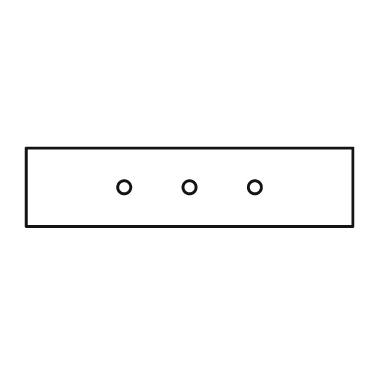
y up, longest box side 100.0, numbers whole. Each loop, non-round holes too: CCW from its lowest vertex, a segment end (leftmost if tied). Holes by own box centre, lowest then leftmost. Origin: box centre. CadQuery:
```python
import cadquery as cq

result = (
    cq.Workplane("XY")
    .moveTo(-50.0, -12.0)
    .lineTo(50.0, -12.0)
    .lineTo(50.0, 12.0)
    .lineTo(-50.0, 12.0)
    .close()
    .moveTo(-20.0, 0.0)
    .circle(2.0)
    .moveTo(0.0, 0.0)
    .circle(2.0)
    .moveTo(20.0, 0.0)
    .circle(2.0)
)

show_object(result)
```